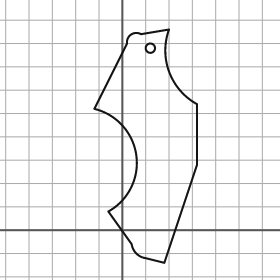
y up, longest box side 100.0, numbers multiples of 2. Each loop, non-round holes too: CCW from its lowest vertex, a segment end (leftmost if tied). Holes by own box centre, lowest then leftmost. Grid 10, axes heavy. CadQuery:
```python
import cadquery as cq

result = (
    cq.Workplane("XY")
    .moveTo(18.0, -14.0)
    .lineTo(32.0, 28.0)
    .lineTo(32.0, 54.0)
    .threePointArc((20.0, 68.0), (20.0, 86.0))
    .lineTo(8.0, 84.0)
    .threePointArc((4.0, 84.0), (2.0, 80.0))
    .lineTo(-12.0, 52.0)
    .threePointArc((6.0, 32.0), (-6.0, 8.0))
    .lineTo(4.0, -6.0)
    .threePointArc((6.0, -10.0), (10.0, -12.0))
    .close()
    .moveTo(12.0, 78.0)
    .circle(2.0)
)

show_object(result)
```